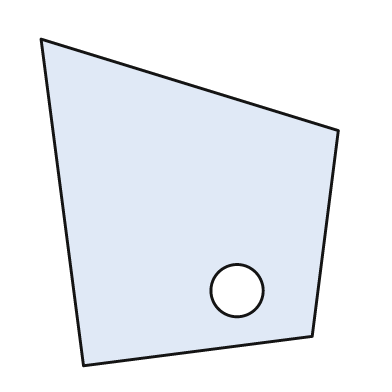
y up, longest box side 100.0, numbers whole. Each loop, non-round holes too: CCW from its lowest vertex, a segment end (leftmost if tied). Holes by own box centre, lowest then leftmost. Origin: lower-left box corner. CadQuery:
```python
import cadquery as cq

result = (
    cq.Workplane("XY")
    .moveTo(13.0, 0.0)
    .lineTo(83.0, 9.0)
    .lineTo(91.0, 72.0)
    .lineTo(0.0, 100.0)
    .close()
    .moveTo(60.0, 23.0)
    .circle(8.0)
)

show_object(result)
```